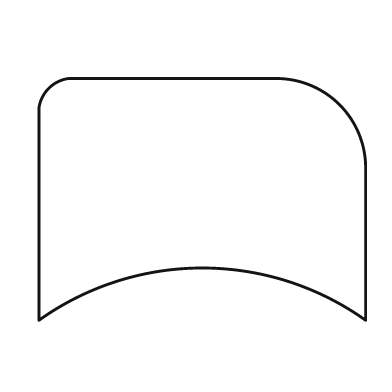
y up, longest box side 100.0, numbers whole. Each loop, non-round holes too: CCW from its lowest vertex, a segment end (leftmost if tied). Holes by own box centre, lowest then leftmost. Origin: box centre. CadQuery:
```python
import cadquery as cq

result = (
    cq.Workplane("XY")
    .moveTo(-50.0, -37.0)
    .threePointArc((0.0, -21.0), (50.0, -37.0))
    .lineTo(50.0, 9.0)
    .threePointArc((42.0, 29.0), (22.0, 37.0))
    .lineTo(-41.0, 37.0)
    .threePointArc((-47.0, 34.0), (-50.0, 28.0))
    .close()
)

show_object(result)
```